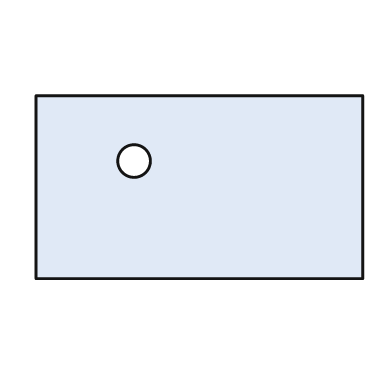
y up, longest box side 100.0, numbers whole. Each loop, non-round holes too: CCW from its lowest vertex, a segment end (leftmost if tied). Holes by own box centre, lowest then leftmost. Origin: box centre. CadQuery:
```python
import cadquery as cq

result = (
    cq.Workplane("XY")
    .moveTo(-50.0, -28.0)
    .lineTo(50.0, -28.0)
    .lineTo(50.0, 28.0)
    .lineTo(-50.0, 28.0)
    .close()
    .moveTo(-20.0, 8.0)
    .circle(5.0)
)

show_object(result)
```